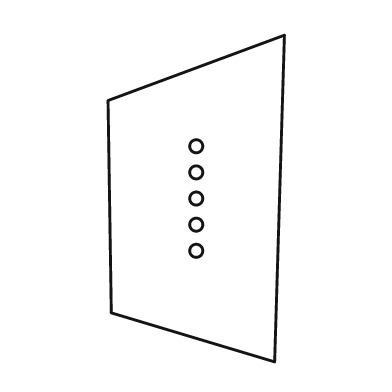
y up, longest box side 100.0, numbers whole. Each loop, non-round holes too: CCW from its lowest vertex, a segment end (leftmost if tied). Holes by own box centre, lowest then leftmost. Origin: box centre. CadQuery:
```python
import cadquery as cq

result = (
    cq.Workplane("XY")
    .moveTo(24.0, -50.0)
    .lineTo(27.0, 50.0)
    .lineTo(-27.0, 30.0)
    .lineTo(-26.0, -35.0)
    .close()
    .moveTo(0.0, -16.0)
    .circle(2.0)
    .moveTo(0.0, -8.0)
    .circle(2.0)
    .moveTo(0.0, 0.0)
    .circle(2.0)
    .moveTo(0.0, 8.0)
    .circle(2.0)
    .moveTo(0.0, 16.0)
    .circle(2.0)
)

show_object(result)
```